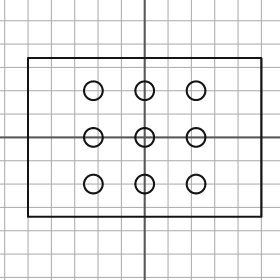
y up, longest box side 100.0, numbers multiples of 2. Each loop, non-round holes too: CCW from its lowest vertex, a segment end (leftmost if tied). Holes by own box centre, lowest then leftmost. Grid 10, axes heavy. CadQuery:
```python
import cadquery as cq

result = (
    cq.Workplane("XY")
    .moveTo(-50.0, -34.0)
    .lineTo(50.0, -34.0)
    .lineTo(50.0, 34.0)
    .lineTo(-50.0, 34.0)
    .close()
    .moveTo(-22.0, -20.0)
    .circle(4.0)
    .moveTo(0.0, -20.0)
    .circle(4.0)
    .moveTo(22.0, -20.0)
    .circle(4.0)
    .moveTo(-22.0, 0.0)
    .circle(4.0)
    .moveTo(0.0, 0.0)
    .circle(4.0)
    .moveTo(22.0, 0.0)
    .circle(4.0)
    .moveTo(-22.0, 20.0)
    .circle(4.0)
    .moveTo(0.0, 20.0)
    .circle(4.0)
    .moveTo(22.0, 20.0)
    .circle(4.0)
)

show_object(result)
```